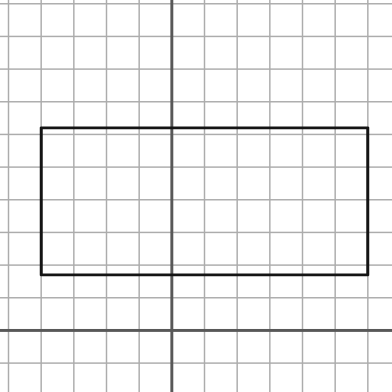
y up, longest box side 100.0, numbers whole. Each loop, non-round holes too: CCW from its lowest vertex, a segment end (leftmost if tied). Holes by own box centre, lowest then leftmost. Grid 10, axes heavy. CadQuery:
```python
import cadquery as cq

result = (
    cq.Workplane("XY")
    .moveTo(-40.0, 17.0)
    .lineTo(60.0, 17.0)
    .lineTo(60.0, 62.0)
    .lineTo(-40.0, 62.0)
    .close()
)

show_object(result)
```